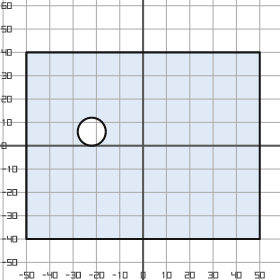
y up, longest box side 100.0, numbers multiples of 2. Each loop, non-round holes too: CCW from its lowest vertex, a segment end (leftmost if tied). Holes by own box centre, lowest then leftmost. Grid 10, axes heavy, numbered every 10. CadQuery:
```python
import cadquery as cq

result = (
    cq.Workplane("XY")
    .moveTo(-50.0, -40.0)
    .lineTo(50.0, -40.0)
    .lineTo(50.0, 40.0)
    .lineTo(-50.0, 40.0)
    .close()
    .moveTo(-22.0, 6.0)
    .circle(6.0)
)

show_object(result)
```